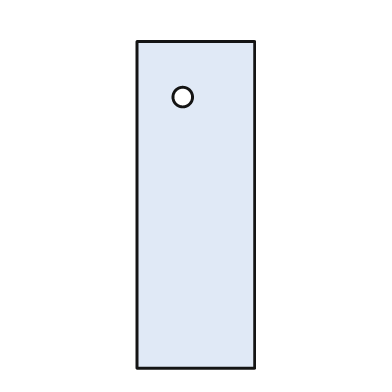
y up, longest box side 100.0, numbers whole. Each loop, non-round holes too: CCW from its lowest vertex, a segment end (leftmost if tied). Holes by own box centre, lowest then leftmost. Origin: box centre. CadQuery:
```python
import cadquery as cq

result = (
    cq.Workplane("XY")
    .moveTo(-18.0, -50.0)
    .lineTo(18.0, -50.0)
    .lineTo(18.0, 50.0)
    .lineTo(-18.0, 50.0)
    .close()
    .moveTo(-4.0, 33.0)
    .circle(3.0)
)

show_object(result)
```